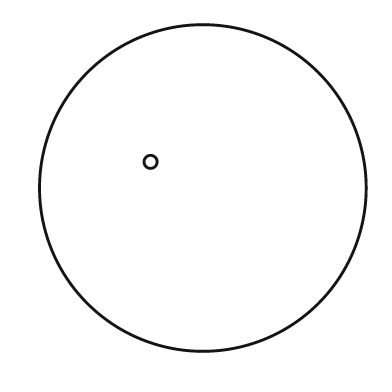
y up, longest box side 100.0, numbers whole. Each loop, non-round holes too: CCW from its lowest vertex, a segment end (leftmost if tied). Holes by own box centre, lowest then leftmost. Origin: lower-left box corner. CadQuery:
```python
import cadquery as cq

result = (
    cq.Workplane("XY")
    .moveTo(50.0, 50.0)
    .circle(50.0)
    .moveTo(34.0, 58.0)
    .circle(2.0)
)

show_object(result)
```